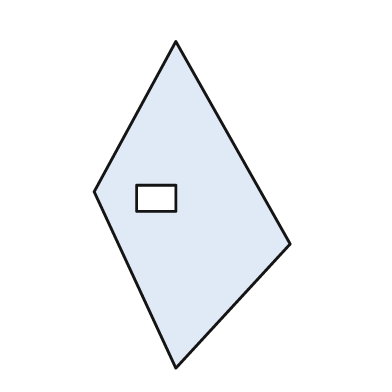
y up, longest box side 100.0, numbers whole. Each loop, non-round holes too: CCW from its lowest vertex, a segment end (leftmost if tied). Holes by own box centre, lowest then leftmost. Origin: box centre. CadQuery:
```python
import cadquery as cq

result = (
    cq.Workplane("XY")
    .moveTo(-5.0, -50.0)
    .lineTo(30.0, -12.0)
    .lineTo(-5.0, 50.0)
    .lineTo(-30.0, 4.0)
    .close()
    .moveTo(-17.0, -2.0)
    .lineTo(-5.0, -2.0)
    .lineTo(-5.0, 6.0)
    .lineTo(-17.0, 6.0)
    .close()
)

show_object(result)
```